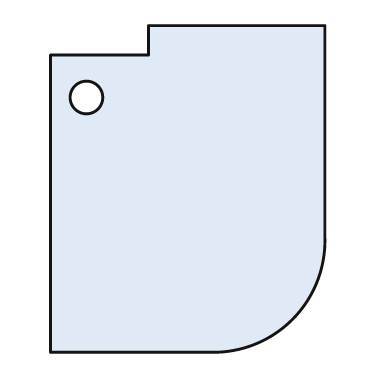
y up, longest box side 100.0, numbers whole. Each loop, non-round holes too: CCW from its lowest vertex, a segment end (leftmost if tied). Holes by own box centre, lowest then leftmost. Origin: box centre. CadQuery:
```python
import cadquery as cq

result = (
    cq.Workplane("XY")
    .moveTo(-42.0, -50.0)
    .lineTo(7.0, -50.0)
    .threePointArc((32.0, -40.0), (42.0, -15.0))
    .lineTo(42.0, 50.0)
    .lineTo(-12.0, 50.0)
    .lineTo(-12.0, 41.0)
    .lineTo(-42.0, 41.0)
    .close()
    .moveTo(-31.0, 28.0)
    .circle(5.0)
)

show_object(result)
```